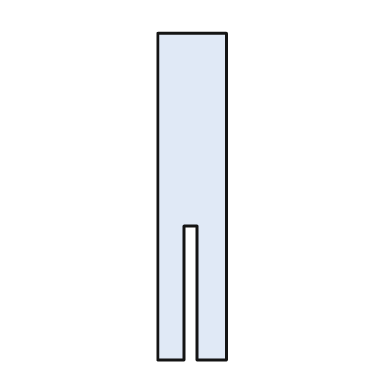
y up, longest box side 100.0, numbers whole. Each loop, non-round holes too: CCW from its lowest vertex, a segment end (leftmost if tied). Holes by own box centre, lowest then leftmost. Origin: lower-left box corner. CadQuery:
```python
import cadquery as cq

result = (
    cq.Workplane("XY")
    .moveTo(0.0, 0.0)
    .lineTo(8.0, 0.0)
    .lineTo(8.0, 41.0)
    .lineTo(12.0, 41.0)
    .lineTo(12.0, 0.0)
    .lineTo(21.0, 0.0)
    .lineTo(21.0, 100.0)
    .lineTo(0.0, 100.0)
    .close()
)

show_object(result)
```